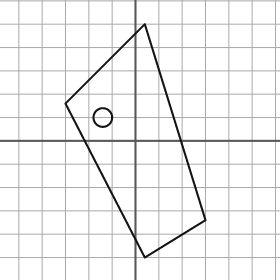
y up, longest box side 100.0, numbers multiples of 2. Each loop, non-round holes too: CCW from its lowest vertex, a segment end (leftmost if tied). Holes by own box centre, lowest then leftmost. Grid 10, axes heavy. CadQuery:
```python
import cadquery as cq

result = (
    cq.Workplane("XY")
    .moveTo(4.0, -50.0)
    .lineTo(30.0, -34.0)
    .lineTo(4.0, 50.0)
    .lineTo(-30.0, 16.0)
    .close()
    .moveTo(-14.0, 10.0)
    .circle(4.0)
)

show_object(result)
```